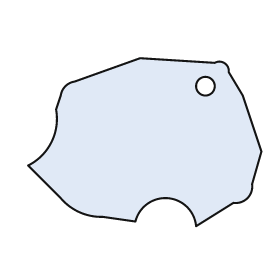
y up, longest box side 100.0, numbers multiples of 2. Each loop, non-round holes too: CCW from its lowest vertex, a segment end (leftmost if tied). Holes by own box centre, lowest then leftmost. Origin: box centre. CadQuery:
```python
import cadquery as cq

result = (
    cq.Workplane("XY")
    .moveTo(22.0, -36.0)
    .lineTo(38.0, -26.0)
    .threePointArc((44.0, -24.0), (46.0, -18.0))
    .lineTo(50.0, -4.0)
    .lineTo(42.0, 20.0)
    .lineTo(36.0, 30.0)
    .threePointArc((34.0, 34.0), (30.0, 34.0))
    .lineTo(-2.0, 36.0)
    .lineTo(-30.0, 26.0)
    .threePointArc((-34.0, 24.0), (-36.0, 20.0))
    .lineTo(-38.0, 14.0)
    .threePointArc((-40.0, 0.0), (-50.0, -10.0))
    .lineTo(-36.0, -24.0)
    .threePointArc((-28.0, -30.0), (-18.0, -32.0))
    .lineTo(-4.0, -34.0)
    .threePointArc((10.0, -24.0), (22.0, -36.0))
    .close()
    .moveTo(26.0, 24.0)
    .circle(4.0)
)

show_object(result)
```